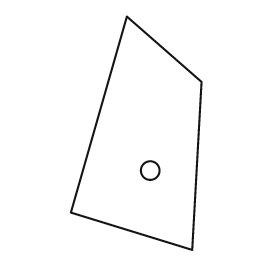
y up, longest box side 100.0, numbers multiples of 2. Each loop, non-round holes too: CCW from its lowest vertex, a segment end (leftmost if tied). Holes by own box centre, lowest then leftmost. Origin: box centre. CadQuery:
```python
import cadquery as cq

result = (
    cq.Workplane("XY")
    .moveTo(24.0, -50.0)
    .lineTo(28.0, 22.0)
    .lineTo(-4.0, 50.0)
    .lineTo(-28.0, -34.0)
    .close()
    .moveTo(6.0, -16.0)
    .circle(4.0)
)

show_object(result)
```